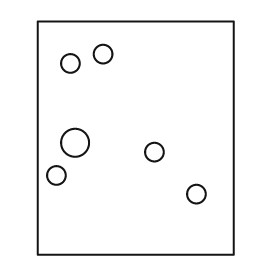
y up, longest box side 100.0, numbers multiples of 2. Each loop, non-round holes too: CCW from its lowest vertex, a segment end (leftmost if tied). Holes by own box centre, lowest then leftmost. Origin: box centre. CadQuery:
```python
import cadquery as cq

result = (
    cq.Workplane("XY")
    .moveTo(-42.0, -50.0)
    .lineTo(42.0, -50.0)
    .lineTo(42.0, 50.0)
    .lineTo(-42.0, 50.0)
    .close()
    .moveTo(26.0, -24.0)
    .circle(4.0)
    .moveTo(-34.0, -16.0)
    .circle(4.0)
    .moveTo(8.0, -6.0)
    .circle(4.0)
    .moveTo(-26.0, -2.0)
    .circle(6.0)
    .moveTo(-28.0, 32.0)
    .circle(4.0)
    .moveTo(-14.0, 36.0)
    .circle(4.0)
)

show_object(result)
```